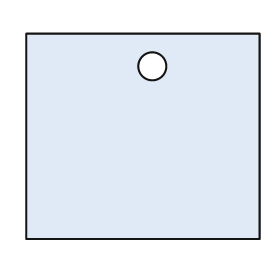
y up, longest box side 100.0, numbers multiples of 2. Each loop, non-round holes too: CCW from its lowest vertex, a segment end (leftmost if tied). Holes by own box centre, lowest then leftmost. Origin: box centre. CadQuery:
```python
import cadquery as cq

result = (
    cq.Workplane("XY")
    .moveTo(-50.0, -44.0)
    .lineTo(50.0, -44.0)
    .lineTo(50.0, 44.0)
    .lineTo(-50.0, 44.0)
    .close()
    .moveTo(4.0, 30.0)
    .circle(6.0)
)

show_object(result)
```